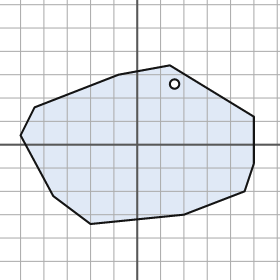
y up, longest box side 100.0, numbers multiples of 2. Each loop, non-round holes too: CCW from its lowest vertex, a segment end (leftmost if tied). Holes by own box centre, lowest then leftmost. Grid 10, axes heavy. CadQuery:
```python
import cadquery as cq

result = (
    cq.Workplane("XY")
    .moveTo(-20.0, -34.0)
    .lineTo(20.0, -30.0)
    .lineTo(46.0, -20.0)
    .lineTo(50.0, -8.0)
    .lineTo(50.0, 12.0)
    .lineTo(14.0, 34.0)
    .lineTo(-8.0, 30.0)
    .lineTo(-44.0, 16.0)
    .lineTo(-50.0, 4.0)
    .lineTo(-36.0, -22.0)
    .close()
    .moveTo(16.0, 26.0)
    .circle(2.0)
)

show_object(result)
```